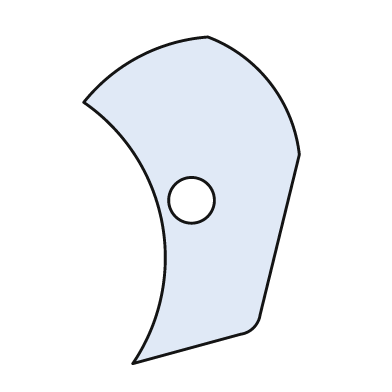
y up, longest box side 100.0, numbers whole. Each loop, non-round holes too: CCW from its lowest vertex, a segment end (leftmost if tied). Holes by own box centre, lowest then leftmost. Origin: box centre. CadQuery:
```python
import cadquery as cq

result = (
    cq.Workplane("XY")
    .moveTo(-18.0, -50.0)
    .lineTo(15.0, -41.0)
    .threePointArc((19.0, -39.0), (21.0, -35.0))
    .lineTo(33.0, 14.0)
    .threePointArc((24.0, 36.0), (5.0, 50.0))
    .threePointArc((-16.0, 44.0), (-33.0, 30.0))
    .threePointArc((-9.0, -7.0), (-18.0, -50.0))
    .close()
    .moveTo(0.0, 0.0)
    .circle(7.0)
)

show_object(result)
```